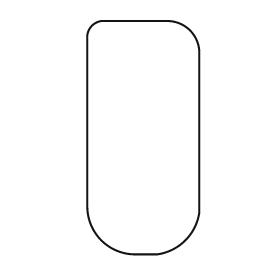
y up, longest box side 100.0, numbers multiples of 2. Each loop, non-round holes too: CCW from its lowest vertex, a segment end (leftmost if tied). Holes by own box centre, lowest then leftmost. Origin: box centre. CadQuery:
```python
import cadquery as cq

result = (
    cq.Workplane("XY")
    .moveTo(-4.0, -50.0)
    .lineTo(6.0, -50.0)
    .threePointArc((18.0, -44.0), (24.0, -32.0))
    .lineTo(24.0, 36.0)
    .threePointArc((20.0, 46.0), (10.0, 50.0))
    .lineTo(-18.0, 50.0)
    .threePointArc((-22.0, 48.0), (-24.0, 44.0))
    .lineTo(-24.0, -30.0)
    .threePointArc((-18.0, -44.0), (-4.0, -50.0))
    .close()
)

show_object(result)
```